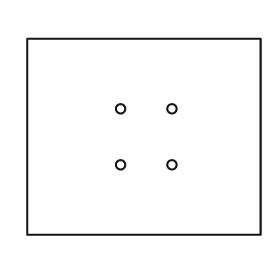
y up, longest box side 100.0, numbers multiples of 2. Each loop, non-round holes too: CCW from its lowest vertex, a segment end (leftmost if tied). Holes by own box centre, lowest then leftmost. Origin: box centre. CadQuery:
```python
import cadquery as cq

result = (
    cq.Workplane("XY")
    .moveTo(-50.0, -42.0)
    .lineTo(50.0, -42.0)
    .lineTo(50.0, 42.0)
    .lineTo(-50.0, 42.0)
    .close()
    .moveTo(-10.0, -12.0)
    .circle(2.0)
    .moveTo(12.0, -12.0)
    .circle(2.0)
    .moveTo(-10.0, 12.0)
    .circle(2.0)
    .moveTo(12.0, 12.0)
    .circle(2.0)
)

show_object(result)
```